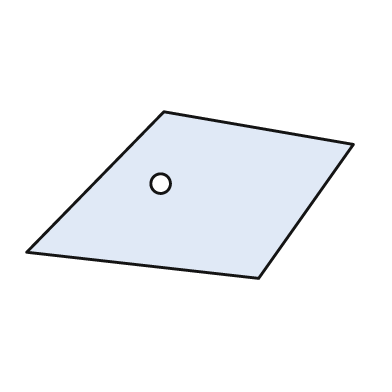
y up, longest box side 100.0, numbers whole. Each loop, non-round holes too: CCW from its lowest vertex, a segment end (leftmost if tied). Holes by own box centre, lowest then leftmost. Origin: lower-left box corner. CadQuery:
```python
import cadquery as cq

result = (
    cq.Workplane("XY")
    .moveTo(71.0, 0.0)
    .lineTo(100.0, 41.0)
    .lineTo(42.0, 51.0)
    .lineTo(0.0, 8.0)
    .close()
    .moveTo(41.0, 29.0)
    .circle(3.0)
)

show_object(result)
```